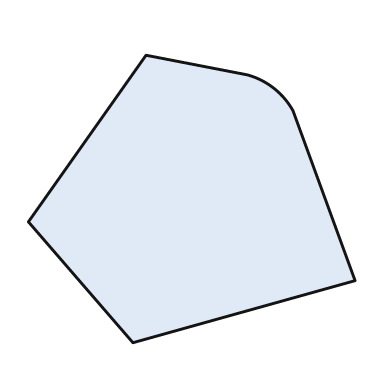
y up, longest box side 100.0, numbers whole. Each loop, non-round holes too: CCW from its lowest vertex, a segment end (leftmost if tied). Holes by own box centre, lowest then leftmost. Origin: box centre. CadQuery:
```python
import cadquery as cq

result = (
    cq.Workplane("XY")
    .moveTo(-18.0, -44.0)
    .lineTo(50.0, -25.0)
    .lineTo(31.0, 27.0)
    .threePointArc((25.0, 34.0), (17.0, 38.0))
    .lineTo(-14.0, 44.0)
    .lineTo(-50.0, -7.0)
    .close()
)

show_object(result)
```